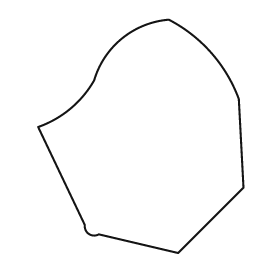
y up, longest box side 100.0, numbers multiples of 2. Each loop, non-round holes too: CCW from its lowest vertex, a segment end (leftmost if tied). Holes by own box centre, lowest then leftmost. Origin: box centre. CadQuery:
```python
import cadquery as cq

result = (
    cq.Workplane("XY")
    .moveTo(16.0, -50.0)
    .lineTo(44.0, -22.0)
    .lineTo(42.0, 16.0)
    .threePointArc((30.0, 36.0), (12.0, 50.0))
    .threePointArc((-8.0, 42.0), (-20.0, 24.0))
    .threePointArc((-30.0, 12.0), (-44.0, 4.0))
    .lineTo(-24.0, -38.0)
    .threePointArc((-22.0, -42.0), (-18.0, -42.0))
    .close()
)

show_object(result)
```